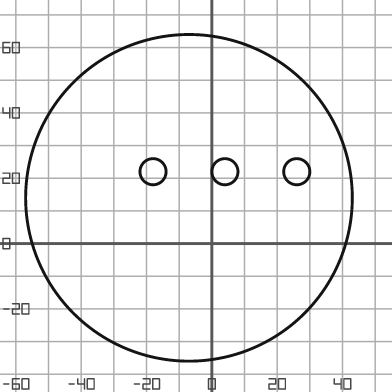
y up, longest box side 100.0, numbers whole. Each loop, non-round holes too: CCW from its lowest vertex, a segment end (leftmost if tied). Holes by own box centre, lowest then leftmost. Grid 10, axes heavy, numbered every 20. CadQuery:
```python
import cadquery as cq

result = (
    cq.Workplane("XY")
    .moveTo(-7.0, 14.0)
    .circle(50.0)
    .moveTo(-18.0, 22.0)
    .circle(4.0)
    .moveTo(4.0, 22.0)
    .circle(4.0)
    .moveTo(26.0, 22.0)
    .circle(4.0)
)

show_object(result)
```